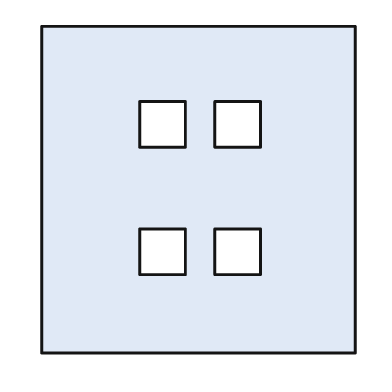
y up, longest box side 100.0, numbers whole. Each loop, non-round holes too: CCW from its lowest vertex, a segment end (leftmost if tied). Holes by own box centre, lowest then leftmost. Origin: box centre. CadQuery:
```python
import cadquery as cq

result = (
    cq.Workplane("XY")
    .moveTo(-48.0, -50.0)
    .lineTo(48.0, -50.0)
    .lineTo(48.0, 50.0)
    .lineTo(-48.0, 50.0)
    .close()
    .moveTo(-18.0, -26.0)
    .lineTo(-4.0, -26.0)
    .lineTo(-4.0, -12.0)
    .lineTo(-18.0, -12.0)
    .close()
    .moveTo(5.0, -26.0)
    .lineTo(19.0, -26.0)
    .lineTo(19.0, -12.0)
    .lineTo(5.0, -12.0)
    .close()
    .moveTo(-18.0, 13.0)
    .lineTo(-4.0, 13.0)
    .lineTo(-4.0, 27.0)
    .lineTo(-18.0, 27.0)
    .close()
    .moveTo(5.0, 13.0)
    .lineTo(19.0, 13.0)
    .lineTo(19.0, 27.0)
    .lineTo(5.0, 27.0)
    .close()
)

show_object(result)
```